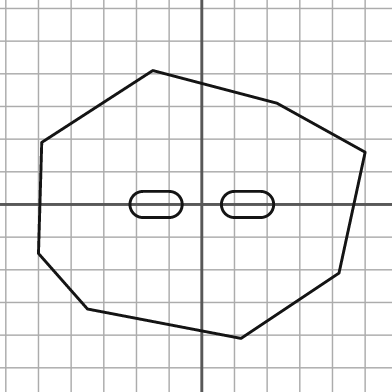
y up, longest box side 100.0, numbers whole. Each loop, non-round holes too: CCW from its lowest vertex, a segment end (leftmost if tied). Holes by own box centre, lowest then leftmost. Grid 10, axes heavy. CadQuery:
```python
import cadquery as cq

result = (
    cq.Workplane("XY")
    .moveTo(12.0, -41.0)
    .lineTo(42.0, -21.0)
    .lineTo(50.0, 16.0)
    .lineTo(23.0, 31.0)
    .lineTo(-15.0, 41.0)
    .lineTo(-49.0, 19.0)
    .lineTo(-50.0, -15.0)
    .lineTo(-35.0, -32.0)
    .close()
    .moveTo(-18.0, -4.0)
    .lineTo(-10.0, -4.0)
    .threePointArc((-6.0, 0.0), (-10.0, 4.0))
    .lineTo(-18.0, 4.0)
    .threePointArc((-22.0, 0.0), (-18.0, -4.0))
    .close()
    .moveTo(10.0, -4.0)
    .lineTo(18.0, -4.0)
    .threePointArc((22.0, 0.0), (18.0, 4.0))
    .lineTo(10.0, 4.0)
    .threePointArc((6.0, 0.0), (10.0, -4.0))
    .close()
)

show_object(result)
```